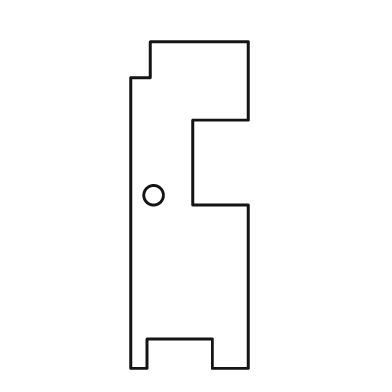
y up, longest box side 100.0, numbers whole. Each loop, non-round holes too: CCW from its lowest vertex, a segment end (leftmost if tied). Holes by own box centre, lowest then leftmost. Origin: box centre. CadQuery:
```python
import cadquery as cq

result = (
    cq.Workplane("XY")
    .moveTo(-18.0, -50.0)
    .lineTo(-13.0, -50.0)
    .lineTo(-13.0, -41.0)
    .lineTo(7.0, -41.0)
    .lineTo(7.0, -50.0)
    .lineTo(18.0, -50.0)
    .lineTo(18.0, 0.0)
    .lineTo(1.0, 0.0)
    .lineTo(1.0, 26.0)
    .lineTo(18.0, 26.0)
    .lineTo(18.0, 50.0)
    .lineTo(-12.0, 50.0)
    .lineTo(-12.0, 39.0)
    .lineTo(-18.0, 39.0)
    .close()
    .moveTo(-11.0, 3.0)
    .circle(3.0)
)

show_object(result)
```